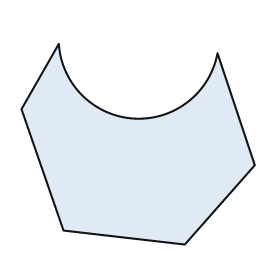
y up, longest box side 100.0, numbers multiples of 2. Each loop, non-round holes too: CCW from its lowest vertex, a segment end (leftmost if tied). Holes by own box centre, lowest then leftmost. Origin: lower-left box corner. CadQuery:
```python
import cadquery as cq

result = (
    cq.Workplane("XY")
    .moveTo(70.0, 0.0)
    .lineTo(100.0, 34.0)
    .lineTo(84.0, 82.0)
    .threePointArc((48.0, 54.0), (16.0, 86.0))
    .lineTo(0.0, 58.0)
    .lineTo(18.0, 6.0)
    .close()
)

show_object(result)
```